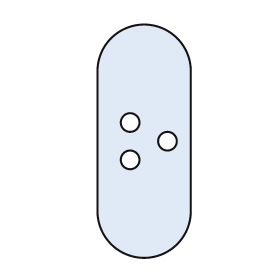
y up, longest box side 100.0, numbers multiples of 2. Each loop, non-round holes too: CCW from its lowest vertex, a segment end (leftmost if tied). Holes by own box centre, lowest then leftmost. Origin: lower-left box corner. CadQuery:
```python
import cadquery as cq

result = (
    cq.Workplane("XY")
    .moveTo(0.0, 20.0)
    .threePointArc((20.0, 0.0), (40.0, 20.0))
    .lineTo(40.0, 80.0)
    .threePointArc((20.0, 100.0), (0.0, 80.0))
    .close()
    .moveTo(14.0, 42.0)
    .circle(4.0)
    .moveTo(30.0, 50.0)
    .circle(4.0)
    .moveTo(14.0, 58.0)
    .circle(4.0)
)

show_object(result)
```